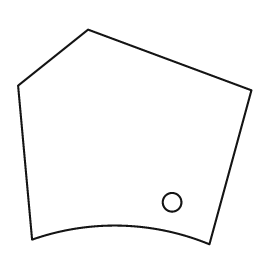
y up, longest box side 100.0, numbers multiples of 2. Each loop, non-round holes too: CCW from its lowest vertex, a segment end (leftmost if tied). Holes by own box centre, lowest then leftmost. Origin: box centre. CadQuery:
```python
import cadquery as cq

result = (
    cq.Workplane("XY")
    .moveTo(32.0, -46.0)
    .lineTo(50.0, 20.0)
    .lineTo(-20.0, 46.0)
    .lineTo(-50.0, 22.0)
    .lineTo(-44.0, -44.0)
    .threePointArc((-6.0, -38.0), (32.0, -46.0))
    .close()
    .moveTo(16.0, -28.0)
    .circle(4.0)
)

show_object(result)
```